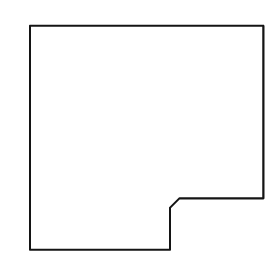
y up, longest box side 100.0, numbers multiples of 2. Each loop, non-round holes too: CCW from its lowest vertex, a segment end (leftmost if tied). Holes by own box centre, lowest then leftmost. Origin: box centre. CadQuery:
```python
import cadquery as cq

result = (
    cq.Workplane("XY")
    .moveTo(-50.0, -48.0)
    .lineTo(10.0, -48.0)
    .lineTo(10.0, -30.0)
    .lineTo(14.0, -26.0)
    .lineTo(50.0, -26.0)
    .lineTo(50.0, 48.0)
    .lineTo(-50.0, 48.0)
    .close()
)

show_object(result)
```